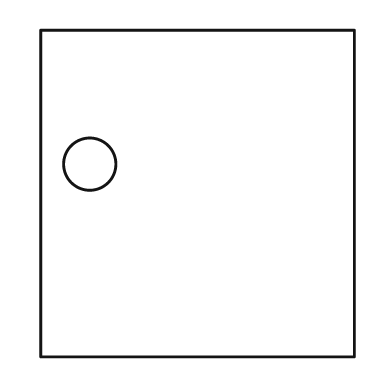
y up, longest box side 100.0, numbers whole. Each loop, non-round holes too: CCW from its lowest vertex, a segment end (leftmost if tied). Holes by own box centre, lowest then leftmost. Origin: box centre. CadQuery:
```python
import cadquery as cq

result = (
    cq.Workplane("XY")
    .moveTo(-48.0, -50.0)
    .lineTo(48.0, -50.0)
    .lineTo(48.0, 50.0)
    .lineTo(-48.0, 50.0)
    .close()
    .moveTo(-33.0, 9.0)
    .circle(8.0)
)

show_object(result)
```